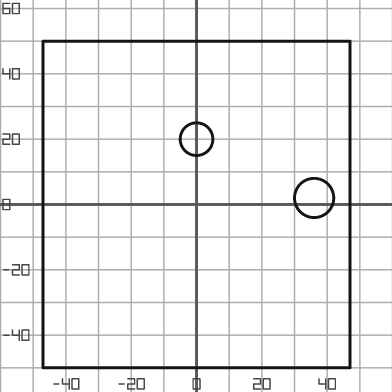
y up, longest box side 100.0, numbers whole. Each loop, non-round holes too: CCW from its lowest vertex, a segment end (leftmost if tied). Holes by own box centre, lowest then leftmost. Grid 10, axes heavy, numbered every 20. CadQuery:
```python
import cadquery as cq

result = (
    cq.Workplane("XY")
    .moveTo(-47.0, -50.0)
    .lineTo(47.0, -50.0)
    .lineTo(47.0, 50.0)
    .lineTo(-47.0, 50.0)
    .close()
    .moveTo(36.0, 2.0)
    .circle(6.0)
    .moveTo(0.0, 20.0)
    .circle(5.0)
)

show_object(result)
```